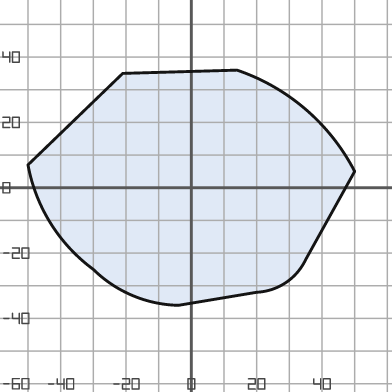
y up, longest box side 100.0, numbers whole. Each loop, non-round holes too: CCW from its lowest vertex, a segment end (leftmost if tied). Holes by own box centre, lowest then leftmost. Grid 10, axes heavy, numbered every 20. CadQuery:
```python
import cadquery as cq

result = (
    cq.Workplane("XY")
    .moveTo(-4.0, -36.0)
    .lineTo(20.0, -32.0)
    .threePointArc((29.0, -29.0), (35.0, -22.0))
    .lineTo(50.0, 5.0)
    .threePointArc((35.0, 24.0), (14.0, 36.0))
    .lineTo(-21.0, 35.0)
    .lineTo(-50.0, 7.0)
    .threePointArc((-43.0, -11.0), (-30.0, -25.0))
    .threePointArc((-18.0, -33.0), (-4.0, -36.0))
    .close()
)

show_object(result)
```